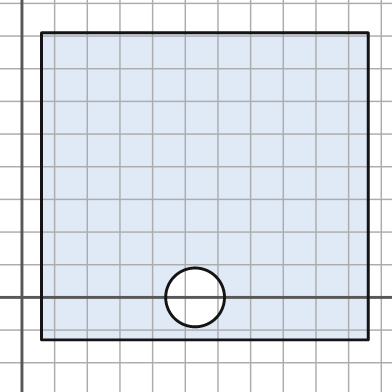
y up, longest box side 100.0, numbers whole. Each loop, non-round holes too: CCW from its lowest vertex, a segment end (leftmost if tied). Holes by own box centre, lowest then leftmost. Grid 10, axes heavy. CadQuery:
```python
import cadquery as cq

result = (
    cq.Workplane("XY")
    .moveTo(6.0, -13.0)
    .lineTo(106.0, -13.0)
    .lineTo(106.0, 81.0)
    .lineTo(6.0, 81.0)
    .close()
    .moveTo(53.0, 0.0)
    .circle(9.0)
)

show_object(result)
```